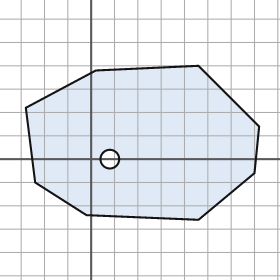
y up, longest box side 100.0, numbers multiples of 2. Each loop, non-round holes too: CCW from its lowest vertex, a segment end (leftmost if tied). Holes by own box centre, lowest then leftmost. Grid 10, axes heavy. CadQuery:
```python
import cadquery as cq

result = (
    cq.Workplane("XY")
    .moveTo(46.0, -26.0)
    .lineTo(70.0, -6.0)
    .lineTo(72.0, 14.0)
    .lineTo(46.0, 40.0)
    .lineTo(2.0, 38.0)
    .lineTo(-28.0, 22.0)
    .lineTo(-24.0, -10.0)
    .lineTo(-2.0, -24.0)
    .close()
    .moveTo(8.0, 0.0)
    .circle(4.0)
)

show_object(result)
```